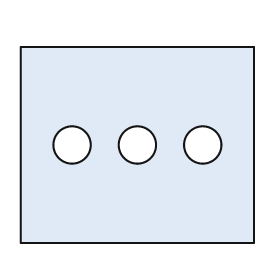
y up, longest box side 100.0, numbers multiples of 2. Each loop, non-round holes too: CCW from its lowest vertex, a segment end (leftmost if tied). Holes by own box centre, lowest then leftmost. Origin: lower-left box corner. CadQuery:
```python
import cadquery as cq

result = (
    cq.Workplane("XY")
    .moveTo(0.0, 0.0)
    .lineTo(100.0, 0.0)
    .lineTo(100.0, 84.0)
    .lineTo(0.0, 84.0)
    .close()
    .moveTo(22.0, 42.0)
    .circle(8.0)
    .moveTo(50.0, 42.0)
    .circle(8.0)
    .moveTo(78.0, 42.0)
    .circle(8.0)
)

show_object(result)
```